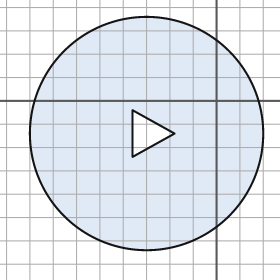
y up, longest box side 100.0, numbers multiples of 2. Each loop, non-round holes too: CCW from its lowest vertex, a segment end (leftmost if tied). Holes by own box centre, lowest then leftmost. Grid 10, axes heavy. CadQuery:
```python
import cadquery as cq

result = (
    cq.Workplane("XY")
    .moveTo(-30.0, -14.0)
    .circle(50.0)
    .moveTo(-36.0, -24.0)
    .lineTo(-18.0, -14.0)
    .lineTo(-36.0, -4.0)
    .close()
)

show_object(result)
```